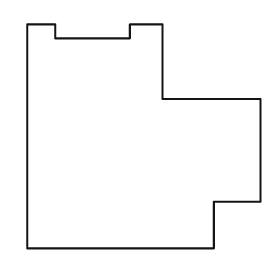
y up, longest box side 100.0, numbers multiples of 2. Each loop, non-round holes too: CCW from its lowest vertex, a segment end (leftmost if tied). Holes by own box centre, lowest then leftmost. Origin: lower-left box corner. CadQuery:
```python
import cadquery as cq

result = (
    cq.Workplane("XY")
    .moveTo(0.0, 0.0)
    .lineTo(80.0, 0.0)
    .lineTo(80.0, 20.0)
    .lineTo(100.0, 20.0)
    .lineTo(100.0, 64.0)
    .lineTo(58.0, 64.0)
    .lineTo(58.0, 96.0)
    .lineTo(44.0, 96.0)
    .lineTo(44.0, 90.0)
    .lineTo(12.0, 90.0)
    .lineTo(12.0, 96.0)
    .lineTo(0.0, 96.0)
    .close()
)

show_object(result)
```